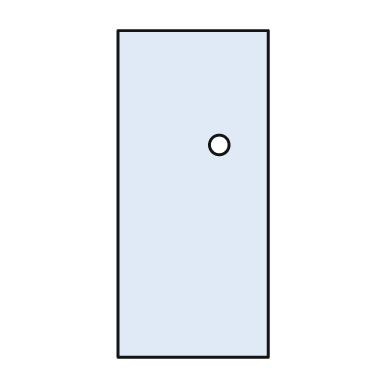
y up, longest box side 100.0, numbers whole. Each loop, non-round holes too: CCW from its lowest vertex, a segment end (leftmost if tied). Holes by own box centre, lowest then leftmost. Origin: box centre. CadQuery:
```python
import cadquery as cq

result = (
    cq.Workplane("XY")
    .moveTo(-23.0, -50.0)
    .lineTo(23.0, -50.0)
    .lineTo(23.0, 50.0)
    .lineTo(-23.0, 50.0)
    .close()
    .moveTo(8.0, 15.0)
    .circle(3.0)
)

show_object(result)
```